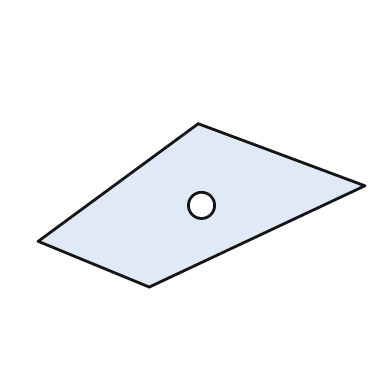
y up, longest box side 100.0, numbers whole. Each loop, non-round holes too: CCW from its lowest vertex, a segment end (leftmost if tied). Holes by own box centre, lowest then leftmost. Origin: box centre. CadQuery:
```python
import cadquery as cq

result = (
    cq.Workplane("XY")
    .moveTo(-16.0, -25.0)
    .lineTo(50.0, 6.0)
    .lineTo(-1.0, 25.0)
    .lineTo(-50.0, -11.0)
    .close()
    .moveTo(0.0, 0.0)
    .circle(4.0)
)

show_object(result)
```